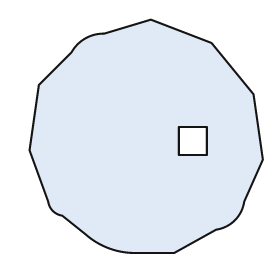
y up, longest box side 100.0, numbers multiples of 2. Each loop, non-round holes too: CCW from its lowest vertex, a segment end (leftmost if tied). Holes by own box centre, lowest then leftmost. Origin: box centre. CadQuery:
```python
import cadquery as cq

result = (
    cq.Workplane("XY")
    .moveTo(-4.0, -50.0)
    .lineTo(12.0, -50.0)
    .lineTo(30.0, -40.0)
    .threePointArc((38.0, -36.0), (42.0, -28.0))
    .lineTo(50.0, -10.0)
    .lineTo(46.0, 18.0)
    .lineTo(28.0, 40.0)
    .lineTo(2.0, 50.0)
    .lineTo(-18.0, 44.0)
    .threePointArc((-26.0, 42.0), (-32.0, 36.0))
    .lineTo(-46.0, 22.0)
    .lineTo(-50.0, -6.0)
    .lineTo(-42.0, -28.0)
    .threePointArc((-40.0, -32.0), (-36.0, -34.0))
    .lineTo(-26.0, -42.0)
    .threePointArc((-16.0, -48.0), (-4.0, -50.0))
    .close()
    .moveTo(14.0, -8.0)
    .lineTo(26.0, -8.0)
    .lineTo(26.0, 4.0)
    .lineTo(14.0, 4.0)
    .close()
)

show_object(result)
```